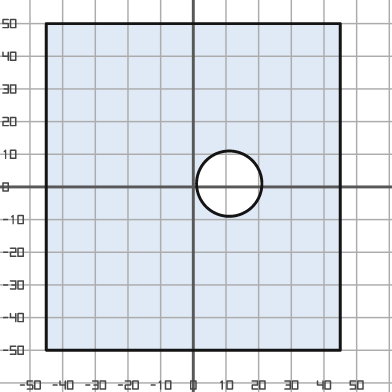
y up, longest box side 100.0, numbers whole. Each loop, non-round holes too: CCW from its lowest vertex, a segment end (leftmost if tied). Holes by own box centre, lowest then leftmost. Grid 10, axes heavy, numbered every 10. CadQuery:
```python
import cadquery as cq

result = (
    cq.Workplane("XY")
    .moveTo(-45.0, -50.0)
    .lineTo(45.0, -50.0)
    .lineTo(45.0, 50.0)
    .lineTo(-45.0, 50.0)
    .close()
    .moveTo(11.0, 1.0)
    .circle(10.0)
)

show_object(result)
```